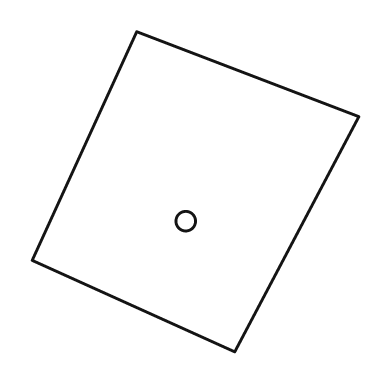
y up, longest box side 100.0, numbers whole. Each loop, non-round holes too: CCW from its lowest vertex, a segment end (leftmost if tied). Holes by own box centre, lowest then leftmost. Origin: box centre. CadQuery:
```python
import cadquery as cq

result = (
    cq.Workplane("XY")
    .moveTo(12.0, -49.0)
    .lineTo(50.0, 23.0)
    .lineTo(-18.0, 49.0)
    .lineTo(-50.0, -21.0)
    .close()
    .moveTo(-3.0, -9.0)
    .circle(3.0)
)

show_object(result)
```